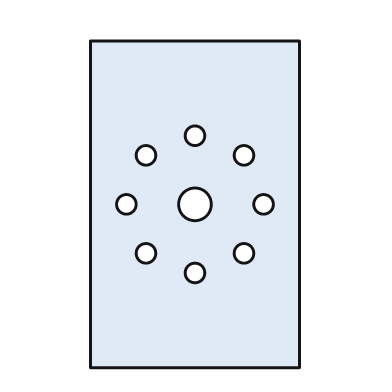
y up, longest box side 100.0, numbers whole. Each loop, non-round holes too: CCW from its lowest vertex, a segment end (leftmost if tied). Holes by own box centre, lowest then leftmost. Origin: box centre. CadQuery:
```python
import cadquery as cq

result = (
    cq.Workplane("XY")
    .moveTo(-32.0, -50.0)
    .lineTo(32.0, -50.0)
    .lineTo(32.0, 50.0)
    .lineTo(-32.0, 50.0)
    .close()
    .moveTo(0.0, -21.0)
    .circle(3.0)
    .moveTo(-15.0, -15.0)
    .circle(3.0)
    .moveTo(15.0, -15.0)
    .circle(3.0)
    .moveTo(-21.0, 0.0)
    .circle(3.0)
    .moveTo(0.0, 0.0)
    .circle(5.0)
    .moveTo(21.0, 0.0)
    .circle(3.0)
    .moveTo(-15.0, 15.0)
    .circle(3.0)
    .moveTo(15.0, 15.0)
    .circle(3.0)
    .moveTo(0.0, 21.0)
    .circle(3.0)
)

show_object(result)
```